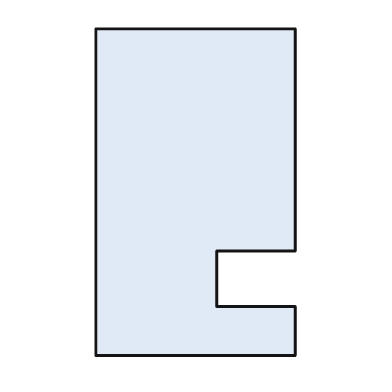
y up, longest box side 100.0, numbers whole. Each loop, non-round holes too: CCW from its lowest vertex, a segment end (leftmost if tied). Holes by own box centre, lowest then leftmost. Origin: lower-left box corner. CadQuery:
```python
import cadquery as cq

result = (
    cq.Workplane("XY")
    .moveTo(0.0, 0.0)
    .lineTo(61.0, 0.0)
    .lineTo(61.0, 15.0)
    .lineTo(37.0, 15.0)
    .lineTo(37.0, 32.0)
    .lineTo(61.0, 32.0)
    .lineTo(61.0, 100.0)
    .lineTo(0.0, 100.0)
    .close()
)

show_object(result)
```